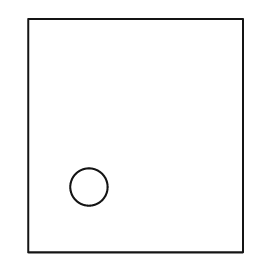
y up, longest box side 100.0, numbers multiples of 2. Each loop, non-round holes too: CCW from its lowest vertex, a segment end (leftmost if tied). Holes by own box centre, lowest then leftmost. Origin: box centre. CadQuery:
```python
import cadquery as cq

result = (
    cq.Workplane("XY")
    .moveTo(-46.0, -50.0)
    .lineTo(46.0, -50.0)
    .lineTo(46.0, 50.0)
    .lineTo(-46.0, 50.0)
    .close()
    .moveTo(-20.0, -22.0)
    .circle(8.0)
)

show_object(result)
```